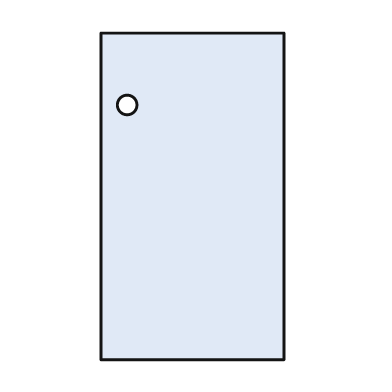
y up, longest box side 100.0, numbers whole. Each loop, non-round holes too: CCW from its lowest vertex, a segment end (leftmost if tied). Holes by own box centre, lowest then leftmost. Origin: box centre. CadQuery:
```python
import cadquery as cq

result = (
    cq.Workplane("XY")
    .moveTo(-28.0, -50.0)
    .lineTo(28.0, -50.0)
    .lineTo(28.0, 50.0)
    .lineTo(-28.0, 50.0)
    .close()
    .moveTo(-20.0, 28.0)
    .circle(3.0)
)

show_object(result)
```